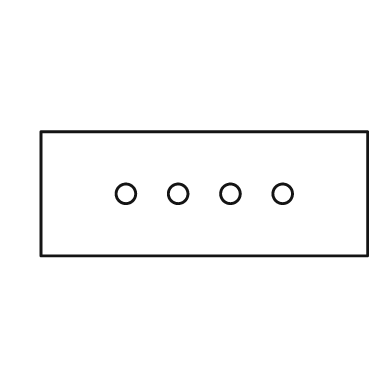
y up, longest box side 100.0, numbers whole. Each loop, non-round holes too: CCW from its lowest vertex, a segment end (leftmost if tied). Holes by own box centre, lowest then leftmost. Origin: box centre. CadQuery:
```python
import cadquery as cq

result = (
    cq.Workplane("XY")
    .moveTo(-50.0, -19.0)
    .lineTo(50.0, -19.0)
    .lineTo(50.0, 19.0)
    .lineTo(-50.0, 19.0)
    .close()
    .moveTo(-24.0, 0.0)
    .circle(3.0)
    .moveTo(-8.0, 0.0)
    .circle(3.0)
    .moveTo(8.0, 0.0)
    .circle(3.0)
    .moveTo(24.0, 0.0)
    .circle(3.0)
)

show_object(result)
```